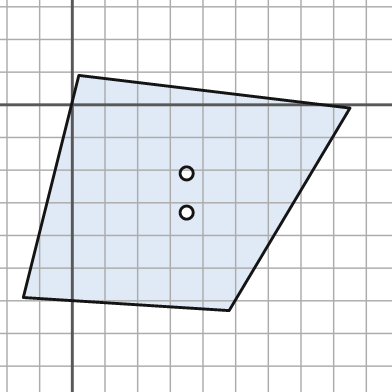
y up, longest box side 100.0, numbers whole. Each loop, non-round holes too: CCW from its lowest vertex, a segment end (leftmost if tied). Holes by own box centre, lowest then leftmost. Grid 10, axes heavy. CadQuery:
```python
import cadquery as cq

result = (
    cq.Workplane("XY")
    .moveTo(48.0, -63.0)
    .lineTo(85.0, -1.0)
    .lineTo(2.0, 9.0)
    .lineTo(-15.0, -59.0)
    .close()
    .moveTo(35.0, -33.0)
    .circle(2.0)
    .moveTo(35.0, -21.0)
    .circle(2.0)
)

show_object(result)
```